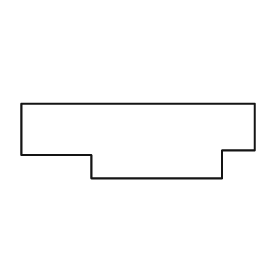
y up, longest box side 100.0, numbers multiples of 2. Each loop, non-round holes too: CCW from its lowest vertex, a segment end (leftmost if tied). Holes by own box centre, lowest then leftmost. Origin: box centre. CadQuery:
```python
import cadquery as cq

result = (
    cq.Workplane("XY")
    .moveTo(-20.0, -16.0)
    .lineTo(36.0, -16.0)
    .lineTo(36.0, -4.0)
    .lineTo(50.0, -4.0)
    .lineTo(50.0, 16.0)
    .lineTo(-50.0, 16.0)
    .lineTo(-50.0, -6.0)
    .lineTo(-20.0, -6.0)
    .close()
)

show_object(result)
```